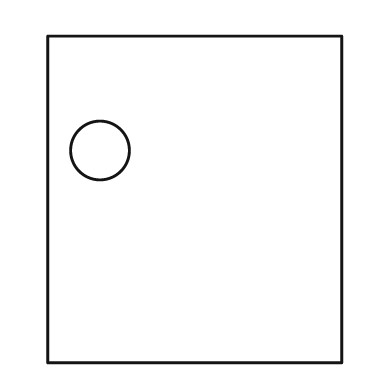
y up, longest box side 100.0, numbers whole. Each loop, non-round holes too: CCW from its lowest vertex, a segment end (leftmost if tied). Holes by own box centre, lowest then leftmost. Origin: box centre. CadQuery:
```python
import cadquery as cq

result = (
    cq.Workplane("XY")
    .moveTo(-45.0, -50.0)
    .lineTo(45.0, -50.0)
    .lineTo(45.0, 50.0)
    .lineTo(-45.0, 50.0)
    .close()
    .moveTo(-29.0, 15.0)
    .circle(9.0)
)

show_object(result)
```